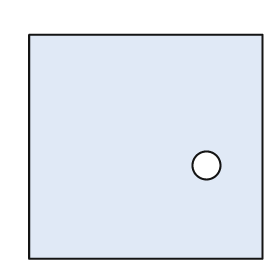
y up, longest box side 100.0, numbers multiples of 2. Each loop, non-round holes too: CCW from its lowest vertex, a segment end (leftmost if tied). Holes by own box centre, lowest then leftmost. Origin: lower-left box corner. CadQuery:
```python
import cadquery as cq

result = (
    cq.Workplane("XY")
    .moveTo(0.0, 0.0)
    .lineTo(100.0, 0.0)
    .lineTo(100.0, 96.0)
    .lineTo(0.0, 96.0)
    .close()
    .moveTo(76.0, 40.0)
    .circle(6.0)
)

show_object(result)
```